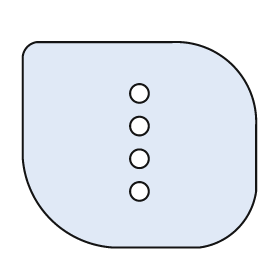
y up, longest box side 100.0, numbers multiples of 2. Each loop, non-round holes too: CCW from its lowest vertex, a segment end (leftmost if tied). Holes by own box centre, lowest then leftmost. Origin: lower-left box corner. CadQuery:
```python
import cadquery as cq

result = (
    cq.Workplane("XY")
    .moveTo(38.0, 0.0)
    .lineTo(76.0, 0.0)
    .threePointArc((92.0, 8.0), (100.0, 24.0))
    .lineTo(100.0, 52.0)
    .threePointArc((90.0, 78.0), (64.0, 88.0))
    .lineTo(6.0, 88.0)
    .threePointArc((2.0, 86.0), (0.0, 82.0))
    .lineTo(0.0, 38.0)
    .threePointArc((12.0, 12.0), (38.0, 0.0))
    .close()
    .moveTo(50.0, 24.0)
    .circle(4.0)
    .moveTo(50.0, 38.0)
    .circle(4.0)
    .moveTo(50.0, 52.0)
    .circle(4.0)
    .moveTo(50.0, 66.0)
    .circle(4.0)
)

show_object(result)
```